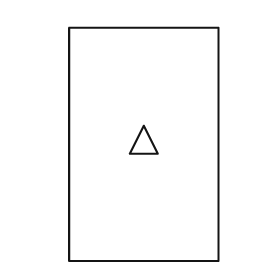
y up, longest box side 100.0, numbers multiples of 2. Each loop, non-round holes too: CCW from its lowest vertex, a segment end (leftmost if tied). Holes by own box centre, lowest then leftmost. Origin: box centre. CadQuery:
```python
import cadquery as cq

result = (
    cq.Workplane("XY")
    .moveTo(-32.0, -50.0)
    .lineTo(32.0, -50.0)
    .lineTo(32.0, 50.0)
    .lineTo(-32.0, 50.0)
    .close()
    .moveTo(-6.0, -4.0)
    .lineTo(6.0, -4.0)
    .lineTo(0.0, 8.0)
    .close()
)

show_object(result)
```